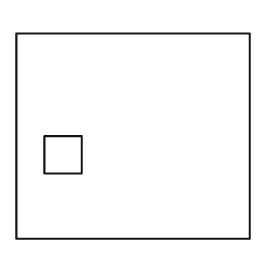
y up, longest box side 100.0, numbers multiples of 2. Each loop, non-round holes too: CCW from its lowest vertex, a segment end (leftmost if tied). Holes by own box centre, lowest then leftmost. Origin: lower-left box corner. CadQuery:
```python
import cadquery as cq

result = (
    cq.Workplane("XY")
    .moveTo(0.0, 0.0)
    .lineTo(100.0, 0.0)
    .lineTo(100.0, 88.0)
    .lineTo(0.0, 88.0)
    .close()
    .moveTo(12.0, 28.0)
    .lineTo(28.0, 28.0)
    .lineTo(28.0, 44.0)
    .lineTo(12.0, 44.0)
    .close()
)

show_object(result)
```